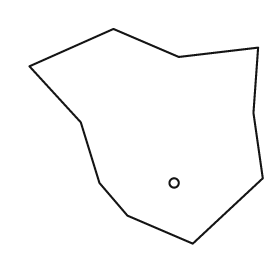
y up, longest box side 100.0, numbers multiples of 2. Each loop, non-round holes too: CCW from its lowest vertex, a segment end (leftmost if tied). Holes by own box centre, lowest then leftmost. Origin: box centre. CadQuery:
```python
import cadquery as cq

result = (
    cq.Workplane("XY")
    .moveTo(20.0, -46.0)
    .lineTo(50.0, -18.0)
    .lineTo(46.0, 10.0)
    .lineTo(48.0, 38.0)
    .lineTo(14.0, 34.0)
    .lineTo(-14.0, 46.0)
    .lineTo(-50.0, 30.0)
    .lineTo(-28.0, 6.0)
    .lineTo(-20.0, -20.0)
    .lineTo(-8.0, -34.0)
    .close()
    .moveTo(12.0, -20.0)
    .circle(2.0)
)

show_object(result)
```